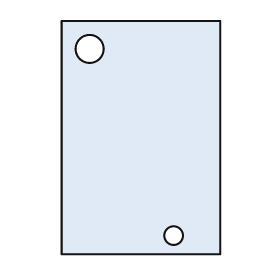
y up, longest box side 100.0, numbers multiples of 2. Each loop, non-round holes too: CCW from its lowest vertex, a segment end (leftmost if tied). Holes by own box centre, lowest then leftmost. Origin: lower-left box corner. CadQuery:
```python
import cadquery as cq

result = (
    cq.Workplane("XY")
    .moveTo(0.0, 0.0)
    .lineTo(68.0, 0.0)
    .lineTo(68.0, 100.0)
    .lineTo(0.0, 100.0)
    .close()
    .moveTo(48.0, 8.0)
    .circle(4.0)
    .moveTo(12.0, 88.0)
    .circle(6.0)
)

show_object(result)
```